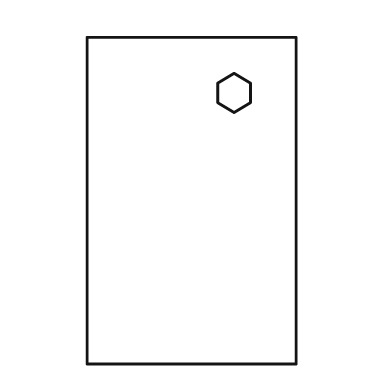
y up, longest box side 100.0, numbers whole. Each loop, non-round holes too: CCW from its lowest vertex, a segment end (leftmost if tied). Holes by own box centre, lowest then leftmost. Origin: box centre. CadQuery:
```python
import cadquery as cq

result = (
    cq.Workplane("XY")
    .moveTo(-32.0, -50.0)
    .lineTo(32.0, -50.0)
    .lineTo(32.0, 50.0)
    .lineTo(-32.0, 50.0)
    .close()
    .moveTo(13.0, 27.0)
    .lineTo(18.0, 30.0)
    .lineTo(18.0, 36.0)
    .lineTo(13.0, 39.0)
    .lineTo(8.0, 36.0)
    .lineTo(8.0, 30.0)
    .close()
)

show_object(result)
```